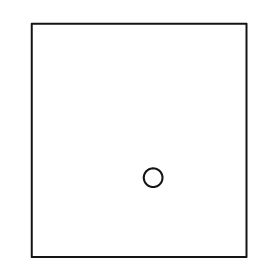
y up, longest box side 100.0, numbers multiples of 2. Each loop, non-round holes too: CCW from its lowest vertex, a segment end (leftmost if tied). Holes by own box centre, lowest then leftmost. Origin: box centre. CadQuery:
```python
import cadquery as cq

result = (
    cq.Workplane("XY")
    .moveTo(-46.0, -50.0)
    .lineTo(46.0, -50.0)
    .lineTo(46.0, 50.0)
    .lineTo(-46.0, 50.0)
    .close()
    .moveTo(6.0, -16.0)
    .circle(4.0)
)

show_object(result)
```